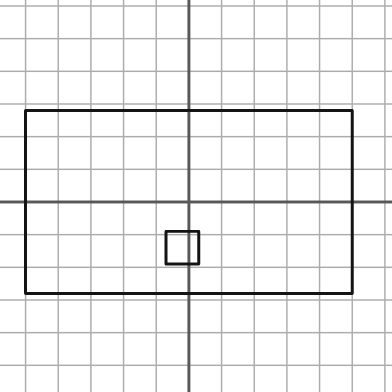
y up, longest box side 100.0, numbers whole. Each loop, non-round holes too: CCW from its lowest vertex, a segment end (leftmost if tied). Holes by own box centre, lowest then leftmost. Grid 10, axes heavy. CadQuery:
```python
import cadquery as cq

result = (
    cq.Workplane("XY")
    .moveTo(-50.0, -28.0)
    .lineTo(50.0, -28.0)
    .lineTo(50.0, 28.0)
    .lineTo(-50.0, 28.0)
    .close()
    .moveTo(-7.0, -19.0)
    .lineTo(3.0, -19.0)
    .lineTo(3.0, -9.0)
    .lineTo(-7.0, -9.0)
    .close()
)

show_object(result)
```